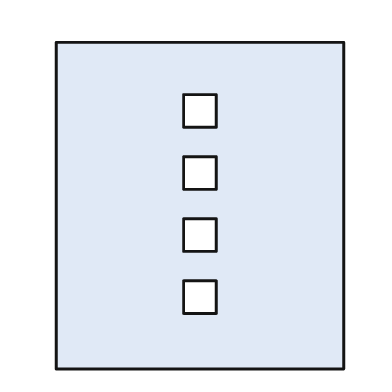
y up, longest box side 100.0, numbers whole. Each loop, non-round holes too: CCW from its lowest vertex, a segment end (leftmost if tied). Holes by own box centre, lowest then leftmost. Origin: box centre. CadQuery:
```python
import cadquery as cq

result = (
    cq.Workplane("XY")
    .moveTo(-44.0, -50.0)
    .lineTo(44.0, -50.0)
    .lineTo(44.0, 50.0)
    .lineTo(-44.0, 50.0)
    .close()
    .moveTo(-5.0, -33.0)
    .lineTo(5.0, -33.0)
    .lineTo(5.0, -23.0)
    .lineTo(-5.0, -23.0)
    .close()
    .moveTo(-5.0, -14.0)
    .lineTo(5.0, -14.0)
    .lineTo(5.0, -4.0)
    .lineTo(-5.0, -4.0)
    .close()
    .moveTo(-5.0, 5.0)
    .lineTo(5.0, 5.0)
    .lineTo(5.0, 15.0)
    .lineTo(-5.0, 15.0)
    .close()
    .moveTo(-5.0, 24.0)
    .lineTo(5.0, 24.0)
    .lineTo(5.0, 34.0)
    .lineTo(-5.0, 34.0)
    .close()
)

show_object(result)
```